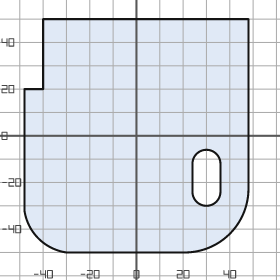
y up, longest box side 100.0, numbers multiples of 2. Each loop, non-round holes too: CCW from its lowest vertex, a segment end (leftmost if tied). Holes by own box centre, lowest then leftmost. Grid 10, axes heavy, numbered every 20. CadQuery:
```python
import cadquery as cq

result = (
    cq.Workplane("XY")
    .moveTo(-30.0, -50.0)
    .lineTo(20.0, -50.0)
    .threePointArc((40.0, -42.0), (48.0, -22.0))
    .lineTo(48.0, 50.0)
    .lineTo(-40.0, 50.0)
    .lineTo(-40.0, 20.0)
    .lineTo(-48.0, 20.0)
    .lineTo(-48.0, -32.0)
    .threePointArc((-42.0, -44.0), (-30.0, -50.0))
    .close()
    .moveTo(24.0, -24.0)
    .threePointArc((30.0, -30.0), (36.0, -24.0))
    .lineTo(36.0, -12.0)
    .threePointArc((30.0, -6.0), (24.0, -12.0))
    .close()
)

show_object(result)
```